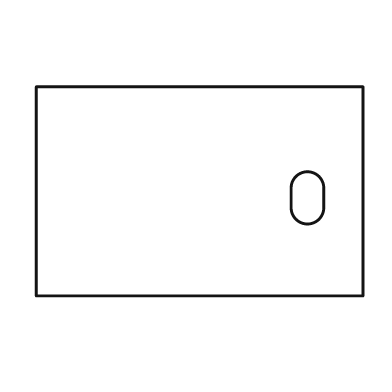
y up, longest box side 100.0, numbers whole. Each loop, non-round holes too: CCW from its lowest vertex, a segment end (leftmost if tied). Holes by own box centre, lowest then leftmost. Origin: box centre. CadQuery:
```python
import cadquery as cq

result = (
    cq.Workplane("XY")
    .moveTo(-50.0, -32.0)
    .lineTo(50.0, -32.0)
    .lineTo(50.0, 32.0)
    .lineTo(-50.0, 32.0)
    .close()
    .moveTo(28.0, -5.0)
    .threePointArc((33.0, -10.0), (38.0, -5.0))
    .lineTo(38.0, 1.0)
    .threePointArc((33.0, 6.0), (28.0, 1.0))
    .close()
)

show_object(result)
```